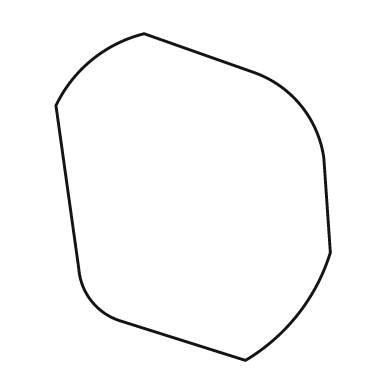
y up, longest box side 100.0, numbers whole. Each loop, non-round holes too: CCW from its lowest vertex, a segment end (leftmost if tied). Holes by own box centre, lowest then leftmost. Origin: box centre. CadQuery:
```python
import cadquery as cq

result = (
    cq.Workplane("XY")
    .moveTo(16.0, -50.0)
    .threePointArc((32.0, -36.0), (42.0, -17.0))
    .lineTo(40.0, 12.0)
    .threePointArc((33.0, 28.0), (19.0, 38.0))
    .lineTo(-15.0, 50.0)
    .threePointArc((-31.0, 42.0), (-42.0, 28.0))
    .lineTo(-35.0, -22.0)
    .threePointArc((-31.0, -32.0), (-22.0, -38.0))
    .close()
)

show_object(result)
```